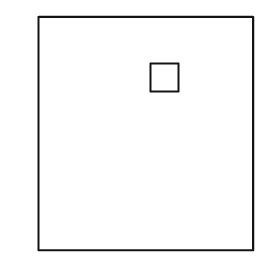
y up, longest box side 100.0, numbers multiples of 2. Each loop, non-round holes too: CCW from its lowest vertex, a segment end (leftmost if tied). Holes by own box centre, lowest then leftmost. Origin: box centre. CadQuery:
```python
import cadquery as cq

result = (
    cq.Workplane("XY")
    .moveTo(-46.0, -50.0)
    .lineTo(46.0, -50.0)
    .lineTo(46.0, 50.0)
    .lineTo(-46.0, 50.0)
    .close()
    .moveTo(2.0, 18.0)
    .lineTo(14.0, 18.0)
    .lineTo(14.0, 30.0)
    .lineTo(2.0, 30.0)
    .close()
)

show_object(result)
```